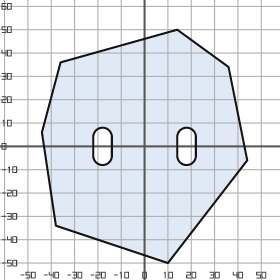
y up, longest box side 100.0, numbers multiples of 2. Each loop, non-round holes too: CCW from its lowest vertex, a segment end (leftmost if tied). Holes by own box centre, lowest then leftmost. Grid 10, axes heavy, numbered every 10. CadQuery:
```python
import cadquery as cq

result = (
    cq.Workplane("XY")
    .moveTo(10.0, -50.0)
    .lineTo(44.0, -6.0)
    .lineTo(36.0, 34.0)
    .lineTo(14.0, 50.0)
    .lineTo(-36.0, 36.0)
    .lineTo(-44.0, 6.0)
    .lineTo(-38.0, -34.0)
    .close()
    .moveTo(-22.0, -4.0)
    .threePointArc((-18.0, -8.0), (-14.0, -4.0))
    .lineTo(-14.0, 4.0)
    .threePointArc((-18.0, 8.0), (-22.0, 4.0))
    .close()
    .moveTo(14.0, -4.0)
    .threePointArc((18.0, -8.0), (22.0, -4.0))
    .lineTo(22.0, 4.0)
    .threePointArc((18.0, 8.0), (14.0, 4.0))
    .close()
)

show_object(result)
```